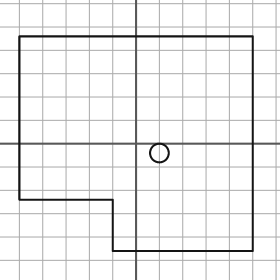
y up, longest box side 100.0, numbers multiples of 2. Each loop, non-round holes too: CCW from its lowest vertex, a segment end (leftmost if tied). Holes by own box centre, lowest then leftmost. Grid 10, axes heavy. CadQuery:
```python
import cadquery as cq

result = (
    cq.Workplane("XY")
    .moveTo(-10.0, -46.0)
    .lineTo(50.0, -46.0)
    .lineTo(50.0, 46.0)
    .lineTo(-50.0, 46.0)
    .lineTo(-50.0, -24.0)
    .lineTo(-10.0, -24.0)
    .close()
    .moveTo(10.0, -4.0)
    .circle(4.0)
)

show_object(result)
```